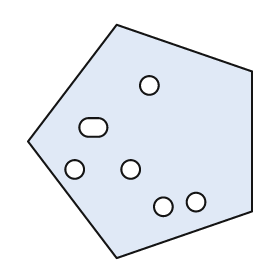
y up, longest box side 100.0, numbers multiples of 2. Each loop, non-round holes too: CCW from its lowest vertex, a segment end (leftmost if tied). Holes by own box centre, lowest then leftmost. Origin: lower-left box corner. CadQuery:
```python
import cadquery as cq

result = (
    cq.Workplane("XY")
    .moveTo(38.0, 0.0)
    .lineTo(96.0, 20.0)
    .lineTo(96.0, 80.0)
    .lineTo(38.0, 100.0)
    .lineTo(0.0, 50.0)
    .close()
    .moveTo(58.0, 22.0)
    .circle(4.0)
    .moveTo(72.0, 24.0)
    .circle(4.0)
    .moveTo(20.0, 38.0)
    .circle(4.0)
    .moveTo(44.0, 38.0)
    .circle(4.0)
    .moveTo(26.0, 52.0)
    .lineTo(30.0, 52.0)
    .threePointArc((34.0, 56.0), (30.0, 60.0))
    .lineTo(26.0, 60.0)
    .threePointArc((22.0, 56.0), (26.0, 52.0))
    .close()
    .moveTo(52.0, 74.0)
    .circle(4.0)
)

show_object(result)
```